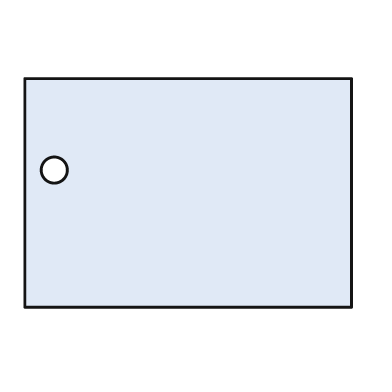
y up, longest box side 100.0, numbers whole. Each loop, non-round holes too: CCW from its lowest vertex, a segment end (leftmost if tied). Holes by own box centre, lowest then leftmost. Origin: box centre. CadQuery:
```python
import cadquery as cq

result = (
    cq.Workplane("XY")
    .moveTo(-50.0, -35.0)
    .lineTo(50.0, -35.0)
    .lineTo(50.0, 35.0)
    .lineTo(-50.0, 35.0)
    .close()
    .moveTo(-41.0, 7.0)
    .circle(4.0)
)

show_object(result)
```